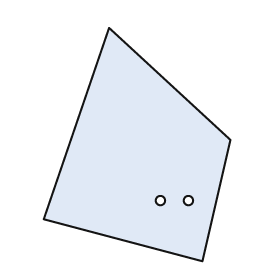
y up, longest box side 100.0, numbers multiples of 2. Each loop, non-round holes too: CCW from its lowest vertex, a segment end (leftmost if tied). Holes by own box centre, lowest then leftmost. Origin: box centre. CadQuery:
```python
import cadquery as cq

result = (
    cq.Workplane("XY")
    .moveTo(28.0, -50.0)
    .lineTo(40.0, 2.0)
    .lineTo(-12.0, 50.0)
    .lineTo(-40.0, -32.0)
    .close()
    .moveTo(10.0, -24.0)
    .circle(2.0)
    .moveTo(22.0, -24.0)
    .circle(2.0)
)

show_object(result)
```